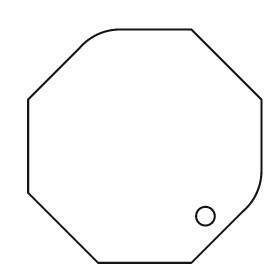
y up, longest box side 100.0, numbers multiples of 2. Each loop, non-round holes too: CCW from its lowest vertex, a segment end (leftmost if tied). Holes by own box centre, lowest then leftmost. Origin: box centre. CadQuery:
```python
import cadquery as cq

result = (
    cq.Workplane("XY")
    .moveTo(-20.0, -50.0)
    .lineTo(20.0, -50.0)
    .lineTo(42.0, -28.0)
    .threePointArc((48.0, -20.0), (50.0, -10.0))
    .lineTo(50.0, 20.0)
    .lineTo(20.0, 50.0)
    .lineTo(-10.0, 50.0)
    .threePointArc((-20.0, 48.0), (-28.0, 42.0))
    .lineTo(-50.0, 20.0)
    .lineTo(-50.0, -20.0)
    .close()
    .moveTo(26.0, -30.0)
    .circle(4.0)
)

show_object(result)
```